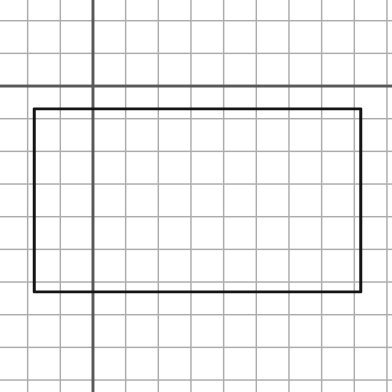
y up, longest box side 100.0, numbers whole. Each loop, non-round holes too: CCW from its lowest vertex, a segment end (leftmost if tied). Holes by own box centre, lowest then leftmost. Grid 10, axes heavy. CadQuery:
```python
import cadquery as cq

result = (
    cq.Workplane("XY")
    .moveTo(-18.0, -63.0)
    .lineTo(82.0, -63.0)
    .lineTo(82.0, -7.0)
    .lineTo(-18.0, -7.0)
    .close()
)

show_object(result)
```